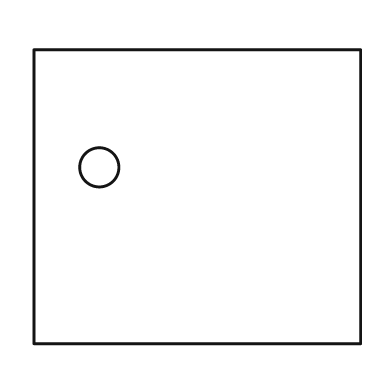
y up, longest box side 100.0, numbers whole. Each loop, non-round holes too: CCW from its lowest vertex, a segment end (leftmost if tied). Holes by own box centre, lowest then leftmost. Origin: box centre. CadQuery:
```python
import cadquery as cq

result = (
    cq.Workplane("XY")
    .moveTo(-50.0, -45.0)
    .lineTo(50.0, -45.0)
    .lineTo(50.0, 45.0)
    .lineTo(-50.0, 45.0)
    .close()
    .moveTo(-30.0, 9.0)
    .circle(6.0)
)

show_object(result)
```